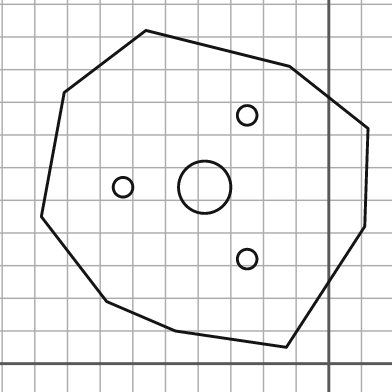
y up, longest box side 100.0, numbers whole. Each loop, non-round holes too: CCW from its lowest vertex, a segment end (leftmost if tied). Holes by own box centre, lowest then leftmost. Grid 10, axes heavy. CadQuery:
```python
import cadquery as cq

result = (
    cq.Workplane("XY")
    .moveTo(-13.0, 5.0)
    .lineTo(11.0, 42.0)
    .lineTo(12.0, 72.0)
    .lineTo(-12.0, 91.0)
    .lineTo(-56.0, 102.0)
    .lineTo(-81.0, 83.0)
    .lineTo(-88.0, 45.0)
    .lineTo(-68.0, 19.0)
    .lineTo(-47.0, 10.0)
    .close()
    .moveTo(-25.0, 32.0)
    .circle(3.0)
    .moveTo(-63.0, 54.0)
    .circle(3.0)
    .moveTo(-38.0, 54.0)
    .circle(8.0)
    .moveTo(-25.0, 76.0)
    .circle(3.0)
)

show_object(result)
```